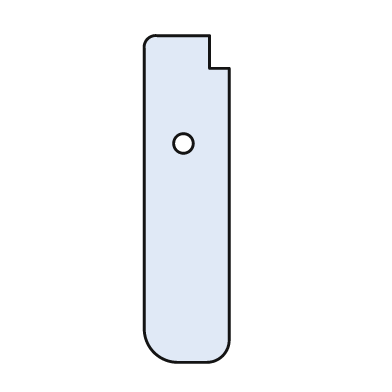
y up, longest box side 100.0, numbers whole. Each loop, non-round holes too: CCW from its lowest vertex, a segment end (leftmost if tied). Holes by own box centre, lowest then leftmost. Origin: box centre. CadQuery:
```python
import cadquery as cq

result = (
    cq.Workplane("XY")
    .moveTo(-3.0, -50.0)
    .lineTo(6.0, -50.0)
    .threePointArc((11.0, -48.0), (13.0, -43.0))
    .lineTo(13.0, 40.0)
    .lineTo(7.0, 40.0)
    .lineTo(7.0, 50.0)
    .lineTo(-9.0, 50.0)
    .threePointArc((-12.0, 49.0), (-13.0, 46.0))
    .lineTo(-13.0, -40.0)
    .threePointArc((-10.0, -47.0), (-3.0, -50.0))
    .close()
    .moveTo(-1.0, 17.0)
    .circle(3.0)
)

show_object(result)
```